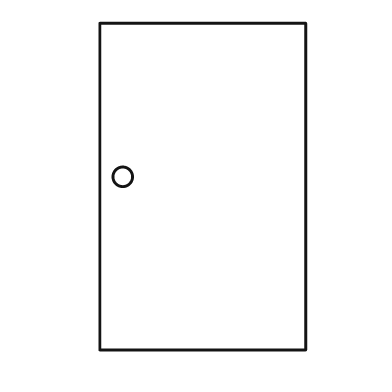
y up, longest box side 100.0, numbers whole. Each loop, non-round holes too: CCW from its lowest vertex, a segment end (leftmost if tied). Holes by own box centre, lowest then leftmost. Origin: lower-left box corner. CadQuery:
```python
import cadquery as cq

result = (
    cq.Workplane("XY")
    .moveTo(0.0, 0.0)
    .lineTo(63.0, 0.0)
    .lineTo(63.0, 100.0)
    .lineTo(0.0, 100.0)
    .close()
    .moveTo(7.0, 53.0)
    .circle(3.0)
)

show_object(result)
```